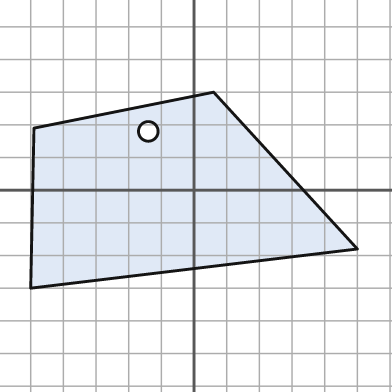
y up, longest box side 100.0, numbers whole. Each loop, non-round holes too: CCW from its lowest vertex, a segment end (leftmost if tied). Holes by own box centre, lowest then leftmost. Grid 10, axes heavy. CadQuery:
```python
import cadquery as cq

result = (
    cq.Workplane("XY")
    .moveTo(-50.0, -30.0)
    .lineTo(50.0, -18.0)
    .lineTo(6.0, 30.0)
    .lineTo(-49.0, 19.0)
    .close()
    .moveTo(-14.0, 18.0)
    .circle(3.0)
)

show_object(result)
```